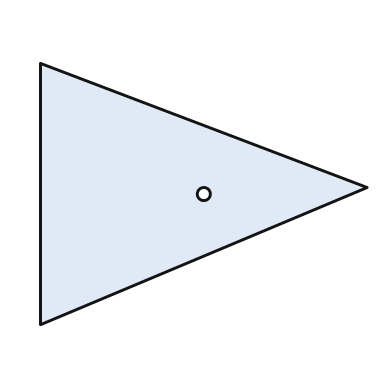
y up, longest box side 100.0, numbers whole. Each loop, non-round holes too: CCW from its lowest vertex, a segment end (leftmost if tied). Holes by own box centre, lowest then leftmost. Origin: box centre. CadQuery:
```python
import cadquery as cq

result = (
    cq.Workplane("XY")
    .moveTo(-50.0, -40.0)
    .lineTo(50.0, 2.0)
    .lineTo(-50.0, 40.0)
    .close()
    .moveTo(0.0, 0.0)
    .circle(2.0)
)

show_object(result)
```